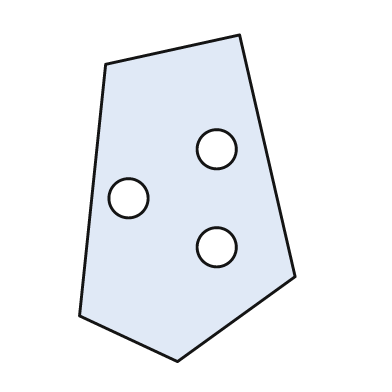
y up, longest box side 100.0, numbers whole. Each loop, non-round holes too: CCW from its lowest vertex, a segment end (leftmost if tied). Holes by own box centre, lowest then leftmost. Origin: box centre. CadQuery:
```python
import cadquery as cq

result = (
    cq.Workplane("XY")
    .moveTo(-3.0, -50.0)
    .lineTo(33.0, -24.0)
    .lineTo(16.0, 50.0)
    .lineTo(-25.0, 41.0)
    .lineTo(-33.0, -36.0)
    .close()
    .moveTo(9.0, -15.0)
    .circle(6.0)
    .moveTo(-18.0, 0.0)
    .circle(6.0)
    .moveTo(9.0, 15.0)
    .circle(6.0)
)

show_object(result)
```